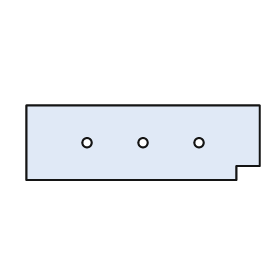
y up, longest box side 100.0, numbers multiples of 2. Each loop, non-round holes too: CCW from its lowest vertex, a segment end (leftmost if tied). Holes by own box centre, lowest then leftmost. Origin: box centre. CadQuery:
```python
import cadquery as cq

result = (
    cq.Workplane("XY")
    .moveTo(-50.0, -16.0)
    .lineTo(40.0, -16.0)
    .lineTo(40.0, -10.0)
    .lineTo(50.0, -10.0)
    .lineTo(50.0, 16.0)
    .lineTo(-50.0, 16.0)
    .close()
    .moveTo(-24.0, 0.0)
    .circle(2.0)
    .moveTo(0.0, 0.0)
    .circle(2.0)
    .moveTo(24.0, 0.0)
    .circle(2.0)
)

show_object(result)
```